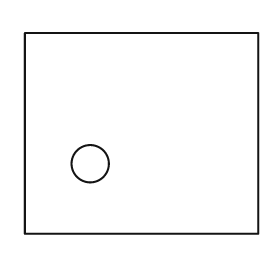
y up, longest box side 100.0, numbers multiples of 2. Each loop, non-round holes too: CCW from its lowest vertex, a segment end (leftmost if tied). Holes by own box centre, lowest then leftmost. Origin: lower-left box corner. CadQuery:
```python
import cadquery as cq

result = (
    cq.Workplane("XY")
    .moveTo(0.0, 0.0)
    .lineTo(100.0, 0.0)
    .lineTo(100.0, 86.0)
    .lineTo(0.0, 86.0)
    .close()
    .moveTo(28.0, 30.0)
    .circle(8.0)
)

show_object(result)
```